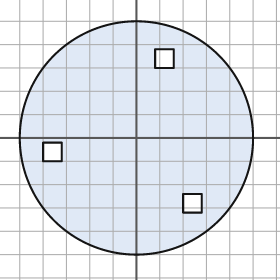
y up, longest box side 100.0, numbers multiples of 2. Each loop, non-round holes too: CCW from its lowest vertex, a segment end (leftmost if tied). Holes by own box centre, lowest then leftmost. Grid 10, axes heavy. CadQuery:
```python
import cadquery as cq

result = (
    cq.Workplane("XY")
    .moveTo(0.0, 0.0)
    .circle(50.0)
    .moveTo(20.0, -32.0)
    .lineTo(28.0, -32.0)
    .lineTo(28.0, -24.0)
    .lineTo(20.0, -24.0)
    .close()
    .moveTo(-40.0, -10.0)
    .lineTo(-32.0, -10.0)
    .lineTo(-32.0, -2.0)
    .lineTo(-40.0, -2.0)
    .close()
    .moveTo(8.0, 30.0)
    .lineTo(16.0, 30.0)
    .lineTo(16.0, 38.0)
    .lineTo(8.0, 38.0)
    .close()
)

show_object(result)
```